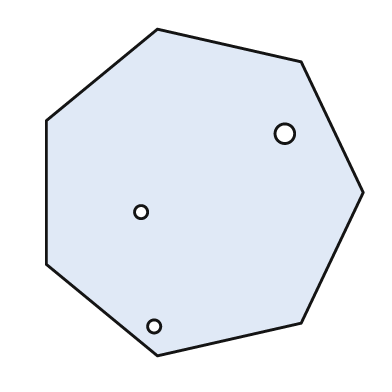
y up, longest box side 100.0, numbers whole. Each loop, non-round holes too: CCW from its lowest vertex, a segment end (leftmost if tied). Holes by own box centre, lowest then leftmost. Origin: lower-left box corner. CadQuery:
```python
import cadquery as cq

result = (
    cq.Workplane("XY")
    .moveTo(34.0, 0.0)
    .lineTo(78.0, 10.0)
    .lineTo(97.0, 50.0)
    .lineTo(78.0, 90.0)
    .lineTo(34.0, 100.0)
    .lineTo(0.0, 72.0)
    .lineTo(0.0, 28.0)
    .close()
    .moveTo(33.0, 9.0)
    .circle(2.0)
    .moveTo(29.0, 44.0)
    .circle(2.0)
    .moveTo(73.0, 68.0)
    .circle(3.0)
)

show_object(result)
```